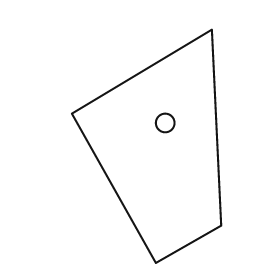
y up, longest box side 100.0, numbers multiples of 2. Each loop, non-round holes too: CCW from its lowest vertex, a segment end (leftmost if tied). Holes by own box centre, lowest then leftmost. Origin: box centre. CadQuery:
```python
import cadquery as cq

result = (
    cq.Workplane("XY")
    .moveTo(4.0, -50.0)
    .lineTo(32.0, -34.0)
    .lineTo(28.0, 50.0)
    .lineTo(-32.0, 14.0)
    .close()
    .moveTo(8.0, 10.0)
    .circle(4.0)
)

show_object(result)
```